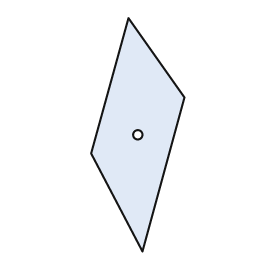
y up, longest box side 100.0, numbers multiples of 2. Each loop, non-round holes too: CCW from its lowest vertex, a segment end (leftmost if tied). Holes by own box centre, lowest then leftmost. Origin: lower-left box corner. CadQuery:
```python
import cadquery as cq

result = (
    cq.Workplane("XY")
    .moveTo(22.0, 0.0)
    .lineTo(40.0, 66.0)
    .lineTo(16.0, 100.0)
    .lineTo(0.0, 42.0)
    .close()
    .moveTo(20.0, 50.0)
    .circle(2.0)
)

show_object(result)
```